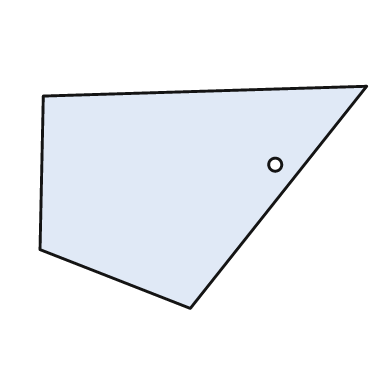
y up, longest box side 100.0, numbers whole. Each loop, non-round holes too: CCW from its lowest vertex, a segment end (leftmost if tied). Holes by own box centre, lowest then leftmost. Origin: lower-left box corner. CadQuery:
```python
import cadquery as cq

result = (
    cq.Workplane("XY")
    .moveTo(46.0, 0.0)
    .lineTo(100.0, 68.0)
    .lineTo(1.0, 65.0)
    .lineTo(0.0, 18.0)
    .close()
    .moveTo(72.0, 44.0)
    .circle(2.0)
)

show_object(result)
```